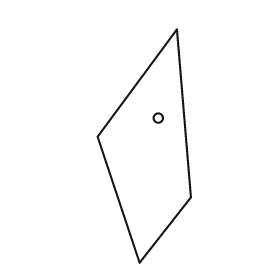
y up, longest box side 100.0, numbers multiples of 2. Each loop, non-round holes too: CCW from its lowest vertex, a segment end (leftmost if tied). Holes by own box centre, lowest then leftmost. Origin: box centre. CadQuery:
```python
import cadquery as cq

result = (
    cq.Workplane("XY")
    .moveTo(-2.0, -50.0)
    .lineTo(20.0, -22.0)
    .lineTo(14.0, 50.0)
    .lineTo(-20.0, 4.0)
    .close()
    .moveTo(6.0, 12.0)
    .circle(2.0)
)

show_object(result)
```